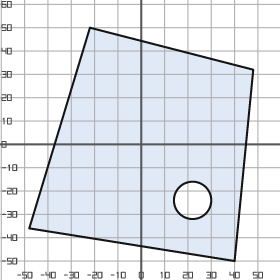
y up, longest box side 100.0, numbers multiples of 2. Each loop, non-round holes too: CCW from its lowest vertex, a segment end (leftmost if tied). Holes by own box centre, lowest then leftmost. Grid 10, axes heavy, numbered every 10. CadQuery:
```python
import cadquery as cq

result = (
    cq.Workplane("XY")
    .moveTo(40.0, -50.0)
    .lineTo(48.0, 32.0)
    .lineTo(-22.0, 50.0)
    .lineTo(-48.0, -36.0)
    .close()
    .moveTo(22.0, -24.0)
    .circle(8.0)
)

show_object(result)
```